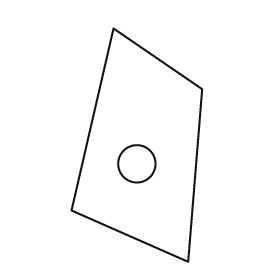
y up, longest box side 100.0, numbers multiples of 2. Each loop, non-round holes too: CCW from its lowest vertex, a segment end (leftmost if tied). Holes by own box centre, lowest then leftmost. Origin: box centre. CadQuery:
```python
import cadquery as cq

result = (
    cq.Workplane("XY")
    .moveTo(22.0, -50.0)
    .lineTo(28.0, 24.0)
    .lineTo(-10.0, 50.0)
    .lineTo(-28.0, -28.0)
    .close()
    .moveTo(0.0, -8.0)
    .circle(8.0)
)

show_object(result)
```